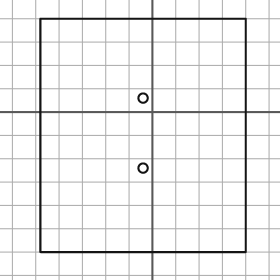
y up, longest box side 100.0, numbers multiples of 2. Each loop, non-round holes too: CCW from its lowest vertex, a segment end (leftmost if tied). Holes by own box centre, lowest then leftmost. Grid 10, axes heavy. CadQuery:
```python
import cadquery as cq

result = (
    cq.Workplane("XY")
    .moveTo(-48.0, -60.0)
    .lineTo(40.0, -60.0)
    .lineTo(40.0, 40.0)
    .lineTo(-48.0, 40.0)
    .close()
    .moveTo(-4.0, -24.0)
    .circle(2.0)
    .moveTo(-4.0, 6.0)
    .circle(2.0)
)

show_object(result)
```